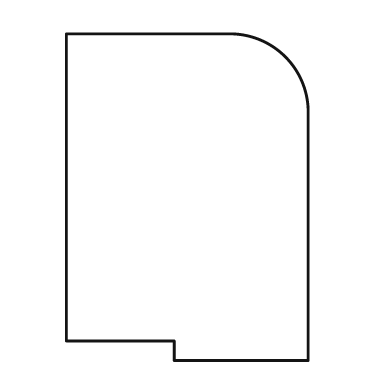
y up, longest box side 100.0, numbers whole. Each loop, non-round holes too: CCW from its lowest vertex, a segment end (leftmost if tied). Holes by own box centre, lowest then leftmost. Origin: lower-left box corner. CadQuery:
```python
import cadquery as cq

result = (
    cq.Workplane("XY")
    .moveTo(33.0, 0.0)
    .lineTo(74.0, 0.0)
    .lineTo(74.0, 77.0)
    .threePointArc((67.0, 93.0), (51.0, 100.0))
    .lineTo(0.0, 100.0)
    .lineTo(0.0, 6.0)
    .lineTo(33.0, 6.0)
    .close()
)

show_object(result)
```